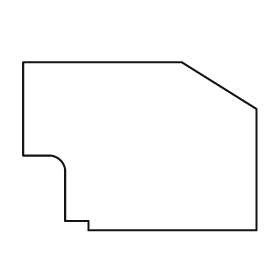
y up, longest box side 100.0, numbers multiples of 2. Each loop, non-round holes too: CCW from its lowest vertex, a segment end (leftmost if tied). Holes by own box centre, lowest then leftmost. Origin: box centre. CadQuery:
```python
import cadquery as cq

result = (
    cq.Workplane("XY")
    .moveTo(-22.0, -36.0)
    .lineTo(50.0, -36.0)
    .lineTo(50.0, 16.0)
    .lineTo(18.0, 36.0)
    .lineTo(-50.0, 36.0)
    .lineTo(-50.0, -4.0)
    .lineTo(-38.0, -4.0)
    .threePointArc((-34.0, -6.0), (-32.0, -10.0))
    .lineTo(-32.0, -32.0)
    .lineTo(-22.0, -32.0)
    .close()
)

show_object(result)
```